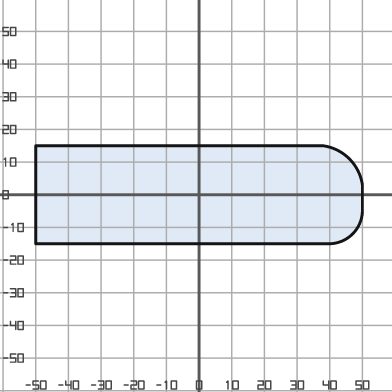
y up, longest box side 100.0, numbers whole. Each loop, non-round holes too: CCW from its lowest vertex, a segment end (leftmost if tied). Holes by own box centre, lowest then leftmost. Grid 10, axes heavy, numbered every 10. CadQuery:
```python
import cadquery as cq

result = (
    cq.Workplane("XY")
    .moveTo(-50.0, -15.0)
    .lineTo(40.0, -15.0)
    .threePointArc((47.0, -12.0), (50.0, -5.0))
    .lineTo(50.0, 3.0)
    .threePointArc((46.0, 11.0), (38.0, 15.0))
    .lineTo(-50.0, 15.0)
    .close()
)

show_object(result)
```